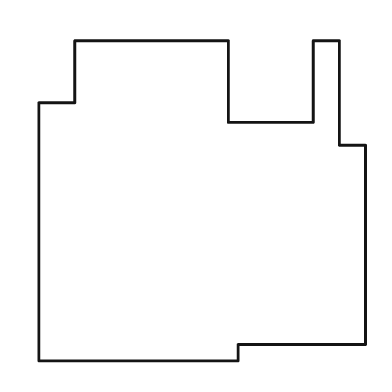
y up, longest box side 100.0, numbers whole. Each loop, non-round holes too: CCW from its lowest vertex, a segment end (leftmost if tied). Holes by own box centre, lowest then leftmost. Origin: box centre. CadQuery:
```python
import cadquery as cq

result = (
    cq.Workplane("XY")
    .moveTo(-50.0, -49.0)
    .lineTo(11.0, -49.0)
    .lineTo(11.0, -44.0)
    .lineTo(50.0, -44.0)
    .lineTo(50.0, 17.0)
    .lineTo(42.0, 17.0)
    .lineTo(42.0, 49.0)
    .lineTo(34.0, 49.0)
    .lineTo(34.0, 24.0)
    .lineTo(8.0, 24.0)
    .lineTo(8.0, 49.0)
    .lineTo(-39.0, 49.0)
    .lineTo(-39.0, 30.0)
    .lineTo(-50.0, 30.0)
    .close()
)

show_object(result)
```